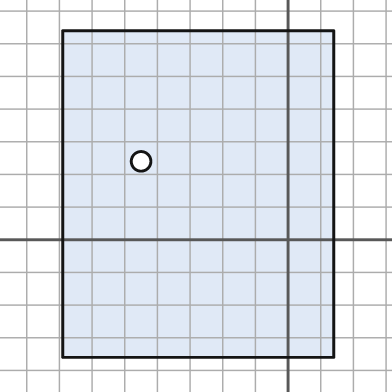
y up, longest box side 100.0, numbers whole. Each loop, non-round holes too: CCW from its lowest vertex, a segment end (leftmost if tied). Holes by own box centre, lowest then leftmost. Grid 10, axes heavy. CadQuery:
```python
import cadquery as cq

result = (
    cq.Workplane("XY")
    .moveTo(-69.0, -36.0)
    .lineTo(14.0, -36.0)
    .lineTo(14.0, 64.0)
    .lineTo(-69.0, 64.0)
    .close()
    .moveTo(-45.0, 24.0)
    .circle(3.0)
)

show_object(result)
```